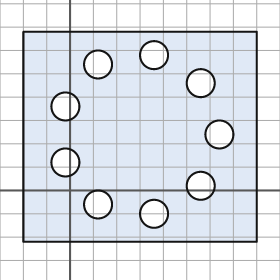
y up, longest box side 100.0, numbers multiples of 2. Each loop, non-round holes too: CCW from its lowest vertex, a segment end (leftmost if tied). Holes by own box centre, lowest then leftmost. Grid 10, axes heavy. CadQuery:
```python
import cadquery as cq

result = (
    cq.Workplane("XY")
    .moveTo(-20.0, -22.0)
    .lineTo(80.0, -22.0)
    .lineTo(80.0, 68.0)
    .lineTo(-20.0, 68.0)
    .close()
    .moveTo(36.0, -10.0)
    .circle(6.0)
    .moveTo(12.0, -6.0)
    .circle(6.0)
    .moveTo(56.0, 2.0)
    .circle(6.0)
    .moveTo(-2.0, 12.0)
    .circle(6.0)
    .moveTo(64.0, 24.0)
    .circle(6.0)
    .moveTo(-2.0, 36.0)
    .circle(6.0)
    .moveTo(56.0, 46.0)
    .circle(6.0)
    .moveTo(12.0, 54.0)
    .circle(6.0)
    .moveTo(36.0, 58.0)
    .circle(6.0)
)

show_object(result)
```